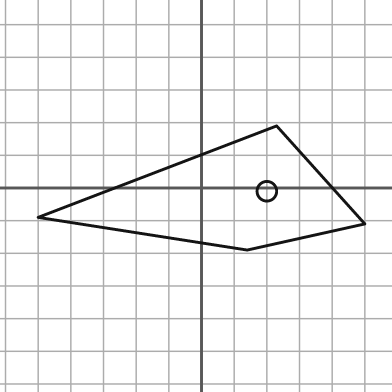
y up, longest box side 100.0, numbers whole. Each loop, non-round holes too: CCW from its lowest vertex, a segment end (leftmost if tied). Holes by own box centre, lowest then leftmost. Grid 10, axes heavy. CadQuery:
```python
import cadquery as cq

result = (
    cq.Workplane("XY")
    .moveTo(14.0, -19.0)
    .lineTo(50.0, -11.0)
    .lineTo(23.0, 19.0)
    .lineTo(-50.0, -9.0)
    .close()
    .moveTo(20.0, -1.0)
    .circle(3.0)
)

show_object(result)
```